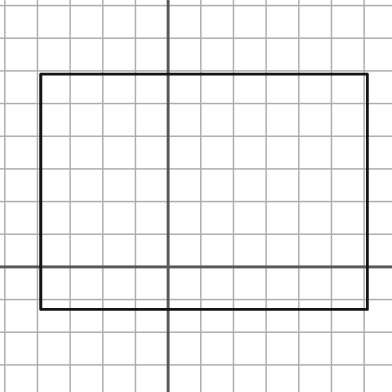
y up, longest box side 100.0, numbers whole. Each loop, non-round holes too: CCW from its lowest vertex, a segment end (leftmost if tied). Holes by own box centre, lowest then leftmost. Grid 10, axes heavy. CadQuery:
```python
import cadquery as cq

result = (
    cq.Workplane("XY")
    .moveTo(-39.0, -13.0)
    .lineTo(61.0, -13.0)
    .lineTo(61.0, 59.0)
    .lineTo(-39.0, 59.0)
    .close()
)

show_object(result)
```